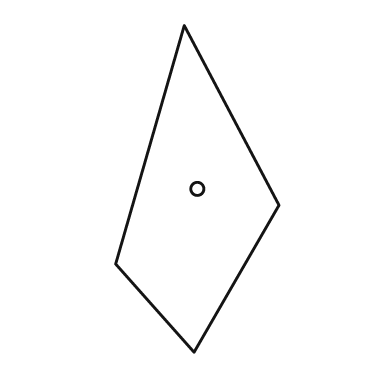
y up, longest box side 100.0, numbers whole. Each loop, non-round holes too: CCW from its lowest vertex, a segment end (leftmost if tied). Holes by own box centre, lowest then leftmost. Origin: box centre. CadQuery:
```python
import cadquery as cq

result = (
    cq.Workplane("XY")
    .moveTo(-1.0, -50.0)
    .lineTo(25.0, -5.0)
    .lineTo(-4.0, 50.0)
    .lineTo(-25.0, -23.0)
    .close()
    .moveTo(0.0, 0.0)
    .circle(2.0)
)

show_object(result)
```